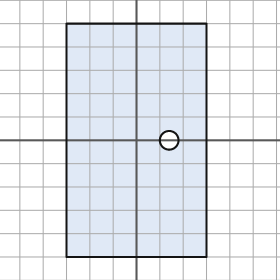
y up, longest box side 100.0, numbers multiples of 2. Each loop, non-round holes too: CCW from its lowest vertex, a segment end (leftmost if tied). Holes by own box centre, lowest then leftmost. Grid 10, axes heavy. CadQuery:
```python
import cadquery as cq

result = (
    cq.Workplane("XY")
    .moveTo(-30.0, -50.0)
    .lineTo(30.0, -50.0)
    .lineTo(30.0, 50.0)
    .lineTo(-30.0, 50.0)
    .close()
    .moveTo(14.0, 0.0)
    .circle(4.0)
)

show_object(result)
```